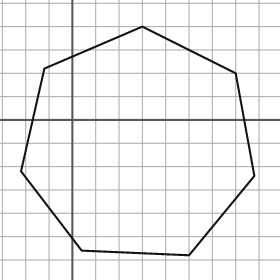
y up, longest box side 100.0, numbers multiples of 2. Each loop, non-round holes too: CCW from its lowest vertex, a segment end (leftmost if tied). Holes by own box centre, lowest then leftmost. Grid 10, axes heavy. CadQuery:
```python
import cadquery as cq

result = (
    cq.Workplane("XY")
    .moveTo(50.0, -58.0)
    .lineTo(78.0, -24.0)
    .lineTo(70.0, 20.0)
    .lineTo(30.0, 40.0)
    .lineTo(-12.0, 22.0)
    .lineTo(-22.0, -22.0)
    .lineTo(4.0, -56.0)
    .close()
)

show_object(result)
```